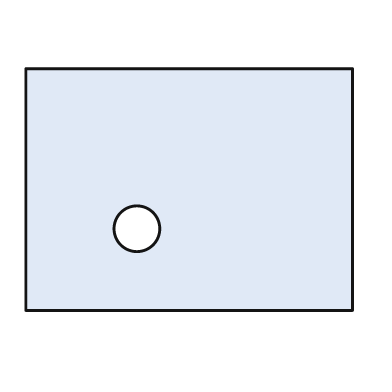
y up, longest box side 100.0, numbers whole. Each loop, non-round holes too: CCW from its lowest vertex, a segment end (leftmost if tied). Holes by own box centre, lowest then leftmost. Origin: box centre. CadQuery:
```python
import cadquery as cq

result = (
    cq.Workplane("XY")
    .moveTo(-50.0, -37.0)
    .lineTo(50.0, -37.0)
    .lineTo(50.0, 37.0)
    .lineTo(-50.0, 37.0)
    .close()
    .moveTo(-16.0, -12.0)
    .circle(7.0)
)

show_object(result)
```